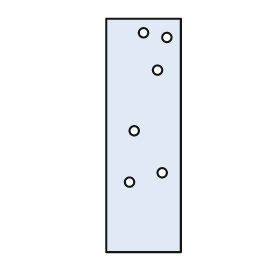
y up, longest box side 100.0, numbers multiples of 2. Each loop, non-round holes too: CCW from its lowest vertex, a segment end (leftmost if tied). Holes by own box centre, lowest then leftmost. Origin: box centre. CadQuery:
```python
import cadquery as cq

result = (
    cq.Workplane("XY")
    .moveTo(-16.0, -50.0)
    .lineTo(16.0, -50.0)
    .lineTo(16.0, 50.0)
    .lineTo(-16.0, 50.0)
    .close()
    .moveTo(-6.0, -20.0)
    .circle(2.0)
    .moveTo(8.0, -16.0)
    .circle(2.0)
    .moveTo(-4.0, 2.0)
    .circle(2.0)
    .moveTo(6.0, 28.0)
    .circle(2.0)
    .moveTo(10.0, 42.0)
    .circle(2.0)
    .moveTo(0.0, 44.0)
    .circle(2.0)
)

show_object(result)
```